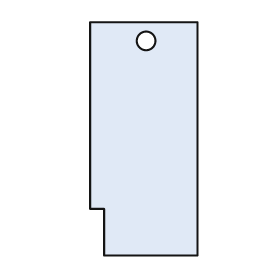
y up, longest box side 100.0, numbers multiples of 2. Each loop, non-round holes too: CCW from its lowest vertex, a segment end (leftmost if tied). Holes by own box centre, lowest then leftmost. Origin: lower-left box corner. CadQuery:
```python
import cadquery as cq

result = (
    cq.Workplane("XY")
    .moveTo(6.0, 0.0)
    .lineTo(46.0, 0.0)
    .lineTo(46.0, 100.0)
    .lineTo(0.0, 100.0)
    .lineTo(0.0, 20.0)
    .lineTo(6.0, 20.0)
    .close()
    .moveTo(24.0, 92.0)
    .circle(4.0)
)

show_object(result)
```